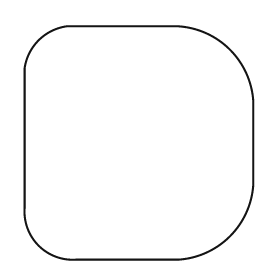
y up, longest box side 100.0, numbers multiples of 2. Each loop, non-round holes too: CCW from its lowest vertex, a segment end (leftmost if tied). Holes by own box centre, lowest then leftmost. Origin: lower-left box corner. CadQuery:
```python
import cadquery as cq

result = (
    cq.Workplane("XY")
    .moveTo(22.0, 0.0)
    .lineTo(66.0, 0.0)
    .threePointArc((88.0, 10.0), (98.0, 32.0))
    .lineTo(98.0, 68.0)
    .threePointArc((88.0, 90.0), (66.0, 100.0))
    .lineTo(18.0, 100.0)
    .threePointArc((6.0, 94.0), (0.0, 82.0))
    .lineTo(0.0, 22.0)
    .threePointArc((6.0, 6.0), (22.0, 0.0))
    .close()
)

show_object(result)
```